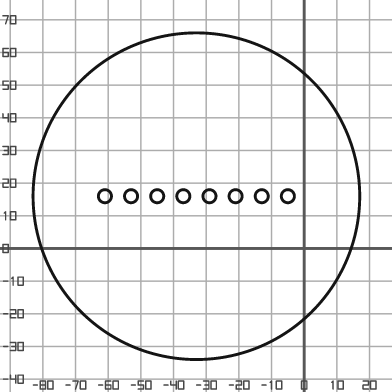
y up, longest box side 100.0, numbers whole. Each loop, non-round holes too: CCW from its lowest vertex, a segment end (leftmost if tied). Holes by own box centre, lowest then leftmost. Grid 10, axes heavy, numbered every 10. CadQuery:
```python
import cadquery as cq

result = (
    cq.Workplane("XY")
    .moveTo(-33.0, 16.0)
    .circle(50.0)
    .moveTo(-61.0, 16.0)
    .circle(2.0)
    .moveTo(-53.0, 16.0)
    .circle(2.0)
    .moveTo(-45.0, 16.0)
    .circle(2.0)
    .moveTo(-37.0, 16.0)
    .circle(2.0)
    .moveTo(-29.0, 16.0)
    .circle(2.0)
    .moveTo(-21.0, 16.0)
    .circle(2.0)
    .moveTo(-13.0, 16.0)
    .circle(2.0)
    .moveTo(-5.0, 16.0)
    .circle(2.0)
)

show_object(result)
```